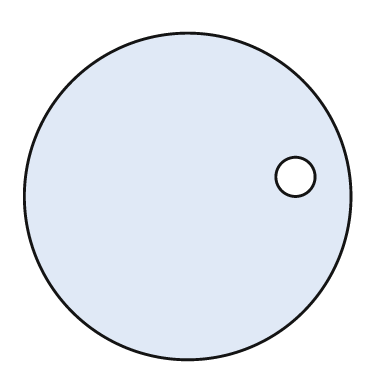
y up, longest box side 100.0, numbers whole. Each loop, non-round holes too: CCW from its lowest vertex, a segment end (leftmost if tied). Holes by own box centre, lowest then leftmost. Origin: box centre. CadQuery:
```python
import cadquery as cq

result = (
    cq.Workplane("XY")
    .moveTo(0.0, 0.0)
    .circle(50.0)
    .moveTo(33.0, 6.0)
    .circle(6.0)
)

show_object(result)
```